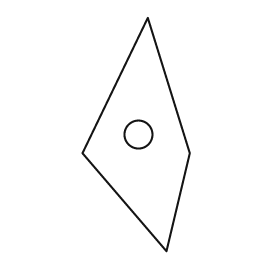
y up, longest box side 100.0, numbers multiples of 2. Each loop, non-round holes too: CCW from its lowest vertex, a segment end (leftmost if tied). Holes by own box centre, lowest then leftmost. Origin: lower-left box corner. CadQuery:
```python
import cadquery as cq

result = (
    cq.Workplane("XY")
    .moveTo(36.0, 0.0)
    .lineTo(46.0, 42.0)
    .lineTo(28.0, 100.0)
    .lineTo(0.0, 42.0)
    .close()
    .moveTo(24.0, 50.0)
    .circle(6.0)
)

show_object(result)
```